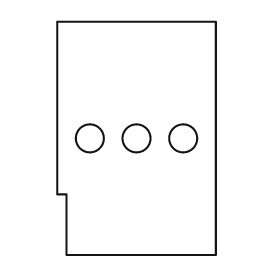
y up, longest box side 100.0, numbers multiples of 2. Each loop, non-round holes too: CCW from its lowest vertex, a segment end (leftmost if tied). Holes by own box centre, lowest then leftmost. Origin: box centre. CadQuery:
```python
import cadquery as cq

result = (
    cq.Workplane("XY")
    .moveTo(-30.0, -50.0)
    .lineTo(34.0, -50.0)
    .lineTo(34.0, 50.0)
    .lineTo(-34.0, 50.0)
    .lineTo(-34.0, -24.0)
    .lineTo(-30.0, -24.0)
    .close()
    .moveTo(-20.0, 0.0)
    .circle(6.0)
    .moveTo(0.0, 0.0)
    .circle(6.0)
    .moveTo(20.0, 0.0)
    .circle(6.0)
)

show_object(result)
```